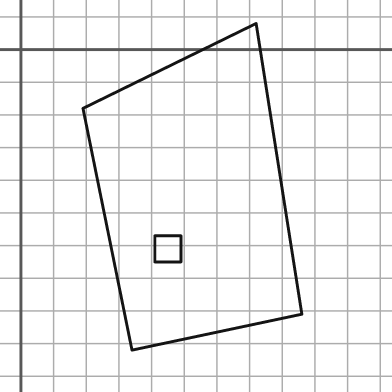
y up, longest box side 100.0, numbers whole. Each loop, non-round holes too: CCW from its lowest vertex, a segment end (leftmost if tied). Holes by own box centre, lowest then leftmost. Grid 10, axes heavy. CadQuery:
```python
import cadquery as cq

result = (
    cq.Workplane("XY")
    .moveTo(34.0, -92.0)
    .lineTo(86.0, -81.0)
    .lineTo(72.0, 8.0)
    .lineTo(19.0, -18.0)
    .close()
    .moveTo(41.0, -65.0)
    .lineTo(49.0, -65.0)
    .lineTo(49.0, -57.0)
    .lineTo(41.0, -57.0)
    .close()
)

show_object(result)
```